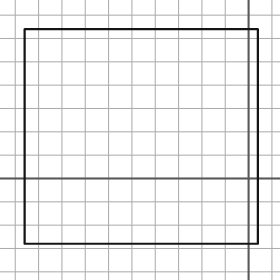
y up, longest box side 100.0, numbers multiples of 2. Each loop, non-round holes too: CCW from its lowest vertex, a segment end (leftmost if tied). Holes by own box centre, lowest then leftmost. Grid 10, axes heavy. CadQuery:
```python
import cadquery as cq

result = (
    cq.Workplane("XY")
    .moveTo(-96.0, -28.0)
    .lineTo(4.0, -28.0)
    .lineTo(4.0, 64.0)
    .lineTo(-96.0, 64.0)
    .close()
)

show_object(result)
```